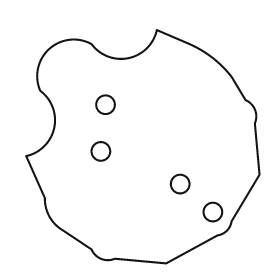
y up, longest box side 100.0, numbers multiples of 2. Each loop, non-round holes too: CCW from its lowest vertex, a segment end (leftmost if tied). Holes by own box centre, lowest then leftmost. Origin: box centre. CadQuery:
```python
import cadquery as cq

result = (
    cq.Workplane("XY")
    .moveTo(10.0, -50.0)
    .lineTo(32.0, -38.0)
    .threePointArc((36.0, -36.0), (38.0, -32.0))
    .lineTo(50.0, -12.0)
    .lineTo(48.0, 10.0)
    .threePointArc((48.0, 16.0), (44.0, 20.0))
    .lineTo(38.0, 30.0)
    .threePointArc((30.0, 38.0), (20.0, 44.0))
    .lineTo(6.0, 50.0)
    .threePointArc((-6.0, 38.0), (-22.0, 44.0))
    .threePointArc((-40.0, 42.0), (-44.0, 24.0))
    .threePointArc((-38.0, 8.0), (-50.0, -4.0))
    .lineTo(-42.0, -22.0)
    .threePointArc((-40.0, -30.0), (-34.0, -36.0))
    .lineTo(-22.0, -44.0)
    .threePointArc((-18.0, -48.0), (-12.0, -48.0))
    .close()
    .moveTo(30.0, -28.0)
    .circle(4.0)
    .moveTo(16.0, -16.0)
    .circle(4.0)
    .moveTo(-18.0, -2.0)
    .circle(4.0)
    .moveTo(-16.0, 18.0)
    .circle(4.0)
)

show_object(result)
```